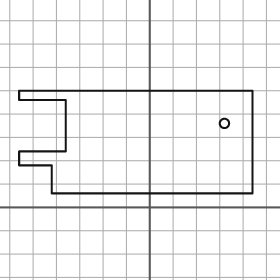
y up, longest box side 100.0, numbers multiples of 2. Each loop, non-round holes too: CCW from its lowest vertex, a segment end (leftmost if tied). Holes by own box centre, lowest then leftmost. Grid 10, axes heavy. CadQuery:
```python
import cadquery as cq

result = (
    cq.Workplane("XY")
    .moveTo(-42.0, 6.0)
    .lineTo(44.0, 6.0)
    .lineTo(44.0, 50.0)
    .lineTo(-56.0, 50.0)
    .lineTo(-56.0, 46.0)
    .lineTo(-36.0, 46.0)
    .lineTo(-36.0, 24.0)
    .lineTo(-56.0, 24.0)
    .lineTo(-56.0, 18.0)
    .lineTo(-42.0, 18.0)
    .close()
    .moveTo(32.0, 36.0)
    .circle(2.0)
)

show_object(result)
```